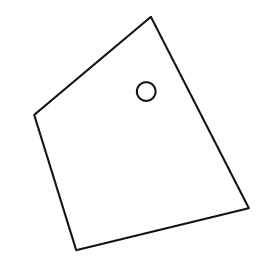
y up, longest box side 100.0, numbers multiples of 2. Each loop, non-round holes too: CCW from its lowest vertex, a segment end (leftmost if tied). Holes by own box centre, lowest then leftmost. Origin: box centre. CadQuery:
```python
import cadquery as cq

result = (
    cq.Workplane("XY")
    .moveTo(-28.0, -50.0)
    .lineTo(46.0, -32.0)
    .lineTo(4.0, 50.0)
    .lineTo(-46.0, 8.0)
    .close()
    .moveTo(2.0, 18.0)
    .circle(4.0)
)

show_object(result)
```